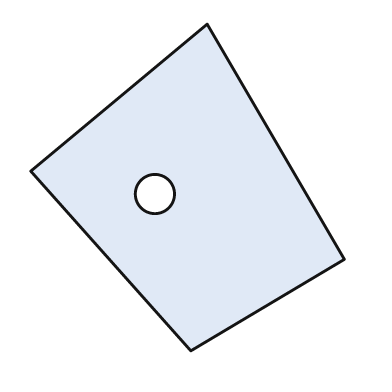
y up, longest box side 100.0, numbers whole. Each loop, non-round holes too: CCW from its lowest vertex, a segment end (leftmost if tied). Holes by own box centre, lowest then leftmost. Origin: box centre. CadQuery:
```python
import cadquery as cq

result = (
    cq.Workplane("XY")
    .moveTo(1.0, -50.0)
    .lineTo(48.0, -22.0)
    .lineTo(6.0, 50.0)
    .lineTo(-48.0, 5.0)
    .close()
    .moveTo(-10.0, -2.0)
    .circle(6.0)
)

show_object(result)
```